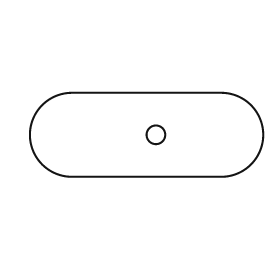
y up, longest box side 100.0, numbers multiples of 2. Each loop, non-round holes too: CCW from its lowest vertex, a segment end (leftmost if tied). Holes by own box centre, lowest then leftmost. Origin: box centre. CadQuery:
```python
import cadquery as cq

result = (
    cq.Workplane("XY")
    .moveTo(-32.0, -18.0)
    .lineTo(32.0, -18.0)
    .threePointArc((50.0, 0.0), (32.0, 18.0))
    .lineTo(-32.0, 18.0)
    .threePointArc((-50.0, 0.0), (-32.0, -18.0))
    .close()
    .moveTo(4.0, 0.0)
    .circle(4.0)
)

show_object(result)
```